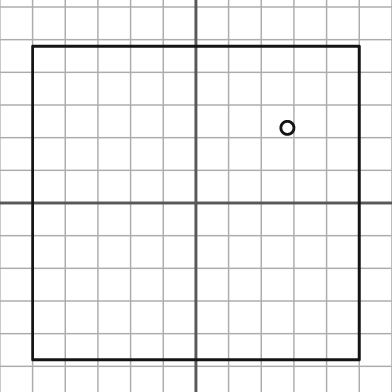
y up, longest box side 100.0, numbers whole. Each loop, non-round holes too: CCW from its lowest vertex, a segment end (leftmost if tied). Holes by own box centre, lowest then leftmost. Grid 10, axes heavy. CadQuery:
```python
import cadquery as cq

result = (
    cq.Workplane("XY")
    .moveTo(-50.0, -48.0)
    .lineTo(50.0, -48.0)
    .lineTo(50.0, 48.0)
    .lineTo(-50.0, 48.0)
    .close()
    .moveTo(28.0, 23.0)
    .circle(2.0)
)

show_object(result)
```